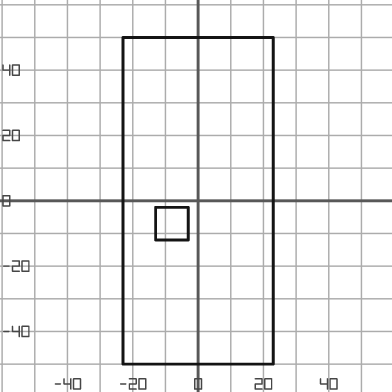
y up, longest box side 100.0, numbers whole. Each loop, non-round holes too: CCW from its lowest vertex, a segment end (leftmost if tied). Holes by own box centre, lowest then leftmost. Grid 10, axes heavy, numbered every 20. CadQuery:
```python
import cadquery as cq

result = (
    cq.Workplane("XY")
    .moveTo(-23.0, -50.0)
    .lineTo(23.0, -50.0)
    .lineTo(23.0, 50.0)
    .lineTo(-23.0, 50.0)
    .close()
    .moveTo(-13.0, -12.0)
    .lineTo(-3.0, -12.0)
    .lineTo(-3.0, -2.0)
    .lineTo(-13.0, -2.0)
    .close()
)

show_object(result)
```